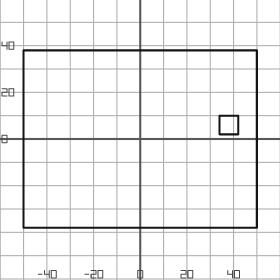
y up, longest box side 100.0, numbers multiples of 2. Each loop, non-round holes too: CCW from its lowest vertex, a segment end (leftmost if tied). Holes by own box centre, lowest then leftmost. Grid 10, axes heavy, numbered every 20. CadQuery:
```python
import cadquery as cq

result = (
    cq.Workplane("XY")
    .moveTo(-50.0, -38.0)
    .lineTo(50.0, -38.0)
    .lineTo(50.0, 38.0)
    .lineTo(-50.0, 38.0)
    .close()
    .moveTo(34.0, 2.0)
    .lineTo(42.0, 2.0)
    .lineTo(42.0, 10.0)
    .lineTo(34.0, 10.0)
    .close()
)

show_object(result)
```